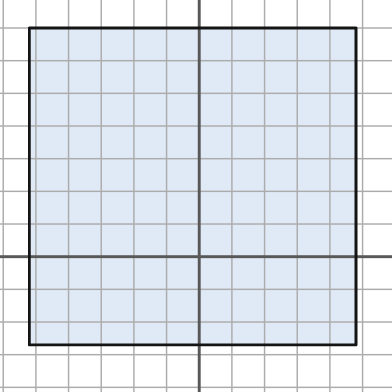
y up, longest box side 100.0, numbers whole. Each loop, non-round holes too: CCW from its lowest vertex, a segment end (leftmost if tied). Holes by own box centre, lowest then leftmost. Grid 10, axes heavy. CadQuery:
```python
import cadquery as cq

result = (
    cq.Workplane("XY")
    .moveTo(-52.0, -27.0)
    .lineTo(48.0, -27.0)
    .lineTo(48.0, 70.0)
    .lineTo(-52.0, 70.0)
    .close()
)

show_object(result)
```